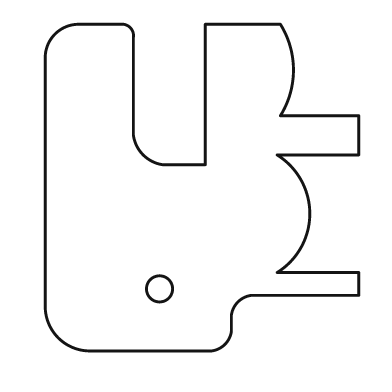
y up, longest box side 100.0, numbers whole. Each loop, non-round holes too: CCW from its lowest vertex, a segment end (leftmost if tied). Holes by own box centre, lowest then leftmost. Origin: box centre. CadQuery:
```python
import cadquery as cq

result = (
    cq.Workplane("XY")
    .moveTo(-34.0, -50.0)
    .lineTo(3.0, -50.0)
    .threePointArc((7.0, -48.0), (9.0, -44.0))
    .lineTo(9.0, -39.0)
    .threePointArc((11.0, -35.0), (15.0, -33.0))
    .lineTo(48.0, -33.0)
    .lineTo(48.0, -26.0)
    .lineTo(23.0, -26.0)
    .threePointArc((33.0, -8.0), (23.0, 10.0))
    .lineTo(48.0, 10.0)
    .lineTo(48.0, 22.0)
    .lineTo(24.0, 22.0)
    .threePointArc((28.0, 36.0), (24.0, 50.0))
    .lineTo(1.0, 50.0)
    .lineTo(1.0, 7.0)
    .lineTo(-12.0, 7.0)
    .threePointArc((-18.0, 10.0), (-21.0, 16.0))
    .lineTo(-21.0, 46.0)
    .threePointArc((-22.0, 49.0), (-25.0, 50.0))
    .lineTo(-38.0, 50.0)
    .threePointArc((-45.0, 47.0), (-48.0, 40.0))
    .lineTo(-48.0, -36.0)
    .threePointArc((-44.0, -46.0), (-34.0, -50.0))
    .close()
    .moveTo(-13.0, -31.0)
    .circle(4.0)
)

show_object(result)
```